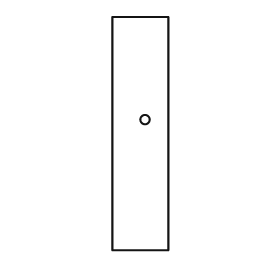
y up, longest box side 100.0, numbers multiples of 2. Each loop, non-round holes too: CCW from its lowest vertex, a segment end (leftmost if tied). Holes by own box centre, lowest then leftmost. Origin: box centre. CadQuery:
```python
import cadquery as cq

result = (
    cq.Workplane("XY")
    .moveTo(-12.0, -50.0)
    .lineTo(12.0, -50.0)
    .lineTo(12.0, 50.0)
    .lineTo(-12.0, 50.0)
    .close()
    .moveTo(2.0, 6.0)
    .circle(2.0)
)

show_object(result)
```